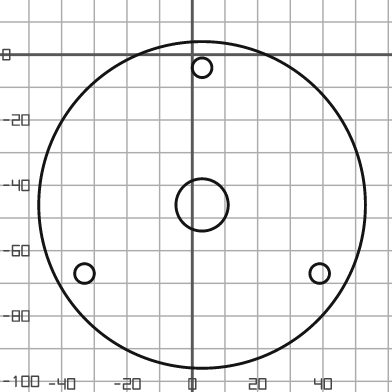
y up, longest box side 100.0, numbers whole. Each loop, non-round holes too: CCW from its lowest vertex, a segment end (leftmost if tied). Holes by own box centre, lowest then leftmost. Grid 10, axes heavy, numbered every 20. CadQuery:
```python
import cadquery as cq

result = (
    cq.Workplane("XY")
    .moveTo(3.0, -46.0)
    .circle(50.0)
    .moveTo(-33.0, -67.0)
    .circle(3.0)
    .moveTo(39.0, -67.0)
    .circle(3.0)
    .moveTo(3.0, -46.0)
    .circle(8.0)
    .moveTo(3.0, -4.0)
    .circle(3.0)
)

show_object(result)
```